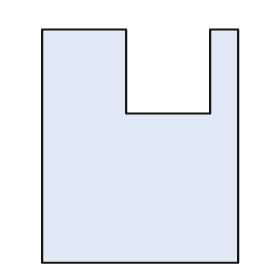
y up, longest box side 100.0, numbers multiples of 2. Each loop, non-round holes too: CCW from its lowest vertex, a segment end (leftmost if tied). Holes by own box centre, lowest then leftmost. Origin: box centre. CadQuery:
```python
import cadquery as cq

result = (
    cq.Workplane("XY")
    .moveTo(-42.0, -50.0)
    .lineTo(42.0, -50.0)
    .lineTo(42.0, 50.0)
    .lineTo(30.0, 50.0)
    .lineTo(30.0, 14.0)
    .lineTo(-6.0, 14.0)
    .lineTo(-6.0, 50.0)
    .lineTo(-42.0, 50.0)
    .close()
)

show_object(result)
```